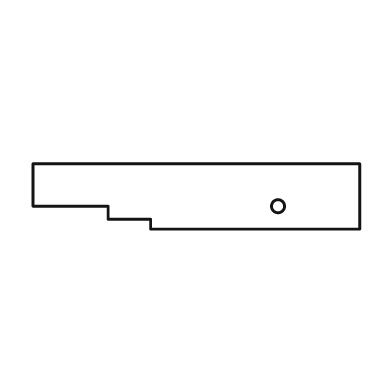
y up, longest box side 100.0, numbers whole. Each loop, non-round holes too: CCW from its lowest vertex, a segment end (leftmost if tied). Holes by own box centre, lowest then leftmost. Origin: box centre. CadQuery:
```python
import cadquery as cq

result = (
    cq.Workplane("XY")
    .moveTo(-14.0, -10.0)
    .lineTo(50.0, -10.0)
    .lineTo(50.0, 10.0)
    .lineTo(-50.0, 10.0)
    .lineTo(-50.0, -3.0)
    .lineTo(-27.0, -3.0)
    .lineTo(-27.0, -7.0)
    .lineTo(-14.0, -7.0)
    .close()
    .moveTo(25.0, -3.0)
    .circle(2.0)
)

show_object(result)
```